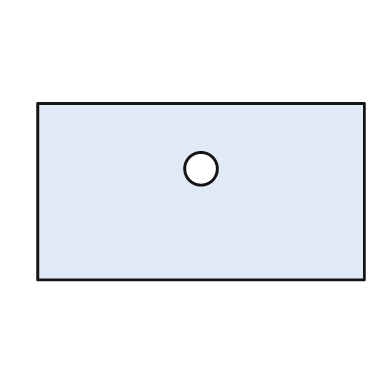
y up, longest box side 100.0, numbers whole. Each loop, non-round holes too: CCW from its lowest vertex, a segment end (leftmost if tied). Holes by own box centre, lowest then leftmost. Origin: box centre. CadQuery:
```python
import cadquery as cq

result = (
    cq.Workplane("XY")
    .moveTo(-50.0, -27.0)
    .lineTo(50.0, -27.0)
    .lineTo(50.0, 27.0)
    .lineTo(-50.0, 27.0)
    .close()
    .moveTo(0.0, 7.0)
    .circle(5.0)
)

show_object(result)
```